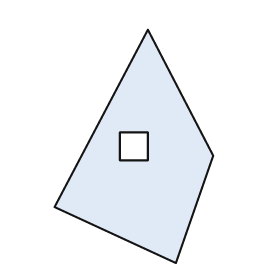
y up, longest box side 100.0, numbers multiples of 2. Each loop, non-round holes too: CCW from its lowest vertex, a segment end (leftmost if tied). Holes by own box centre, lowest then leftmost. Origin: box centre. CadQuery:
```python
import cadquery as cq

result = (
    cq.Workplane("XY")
    .moveTo(18.0, -50.0)
    .lineTo(34.0, -4.0)
    .lineTo(6.0, 50.0)
    .lineTo(-34.0, -26.0)
    .close()
    .moveTo(-6.0, -6.0)
    .lineTo(6.0, -6.0)
    .lineTo(6.0, 6.0)
    .lineTo(-6.0, 6.0)
    .close()
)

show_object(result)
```